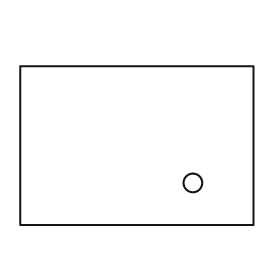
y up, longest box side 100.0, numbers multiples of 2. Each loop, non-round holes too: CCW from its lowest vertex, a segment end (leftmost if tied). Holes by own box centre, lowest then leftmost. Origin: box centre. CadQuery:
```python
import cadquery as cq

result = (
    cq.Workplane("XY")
    .moveTo(-50.0, -34.0)
    .lineTo(50.0, -34.0)
    .lineTo(50.0, 34.0)
    .lineTo(-50.0, 34.0)
    .close()
    .moveTo(24.0, -16.0)
    .circle(4.0)
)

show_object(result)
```